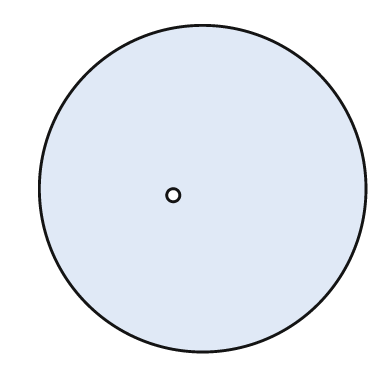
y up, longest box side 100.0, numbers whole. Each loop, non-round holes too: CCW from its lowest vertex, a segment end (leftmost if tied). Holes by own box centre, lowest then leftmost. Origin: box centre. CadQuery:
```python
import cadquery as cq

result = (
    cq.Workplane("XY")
    .moveTo(0.0, 0.0)
    .circle(50.0)
    .moveTo(-9.0, -2.0)
    .circle(2.0)
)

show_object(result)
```